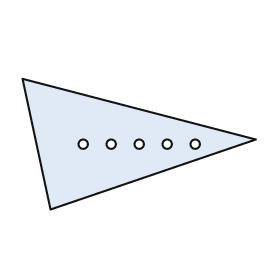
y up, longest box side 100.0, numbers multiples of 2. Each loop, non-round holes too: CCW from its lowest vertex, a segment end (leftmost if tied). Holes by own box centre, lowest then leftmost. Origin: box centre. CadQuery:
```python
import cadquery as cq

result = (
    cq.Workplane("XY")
    .moveTo(-38.0, -28.0)
    .lineTo(50.0, 2.0)
    .lineTo(-50.0, 28.0)
    .close()
    .moveTo(-24.0, 0.0)
    .circle(2.0)
    .moveTo(-12.0, 0.0)
    .circle(2.0)
    .moveTo(0.0, 0.0)
    .circle(2.0)
    .moveTo(12.0, 0.0)
    .circle(2.0)
    .moveTo(24.0, 0.0)
    .circle(2.0)
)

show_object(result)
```